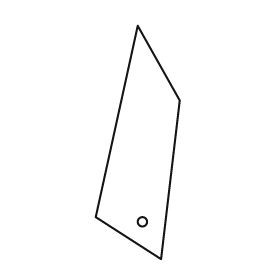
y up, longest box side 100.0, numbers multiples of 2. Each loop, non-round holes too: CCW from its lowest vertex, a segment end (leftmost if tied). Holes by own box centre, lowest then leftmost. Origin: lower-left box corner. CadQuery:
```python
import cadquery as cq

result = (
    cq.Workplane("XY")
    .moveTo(28.0, 0.0)
    .lineTo(36.0, 68.0)
    .lineTo(18.0, 100.0)
    .lineTo(0.0, 18.0)
    .close()
    .moveTo(20.0, 16.0)
    .circle(2.0)
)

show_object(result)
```